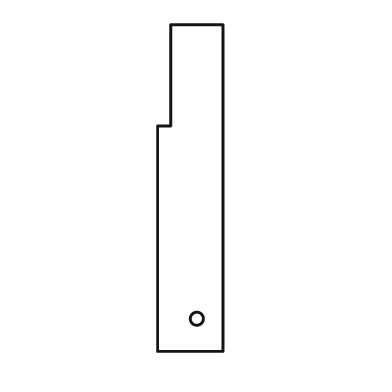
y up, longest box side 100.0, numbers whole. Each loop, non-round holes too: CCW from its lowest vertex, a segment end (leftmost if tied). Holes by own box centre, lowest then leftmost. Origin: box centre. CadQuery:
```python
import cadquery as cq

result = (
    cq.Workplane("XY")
    .moveTo(-10.0, -50.0)
    .lineTo(10.0, -50.0)
    .lineTo(10.0, 50.0)
    .lineTo(-6.0, 50.0)
    .lineTo(-6.0, 19.0)
    .lineTo(-10.0, 19.0)
    .close()
    .moveTo(2.0, -40.0)
    .circle(2.0)
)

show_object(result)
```